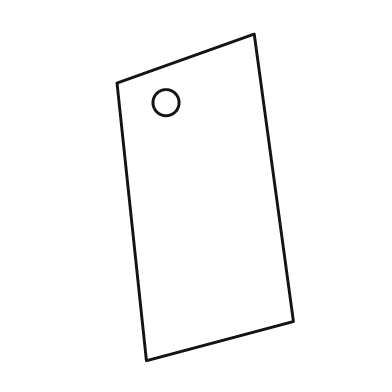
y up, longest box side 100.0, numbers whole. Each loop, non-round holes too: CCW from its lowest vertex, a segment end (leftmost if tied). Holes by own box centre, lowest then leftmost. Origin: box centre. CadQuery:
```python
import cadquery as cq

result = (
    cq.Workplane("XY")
    .moveTo(-18.0, -50.0)
    .lineTo(27.0, -38.0)
    .lineTo(15.0, 50.0)
    .lineTo(-27.0, 35.0)
    .close()
    .moveTo(-12.0, 29.0)
    .circle(4.0)
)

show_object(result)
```